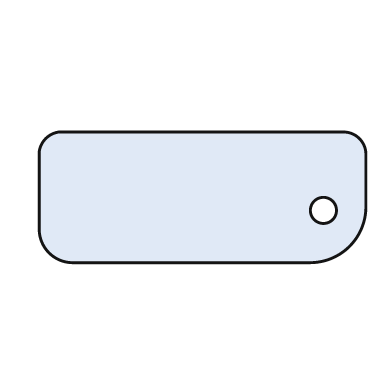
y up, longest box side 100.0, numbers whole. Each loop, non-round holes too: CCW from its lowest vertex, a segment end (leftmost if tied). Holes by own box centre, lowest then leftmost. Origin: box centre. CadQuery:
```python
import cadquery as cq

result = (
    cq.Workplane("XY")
    .moveTo(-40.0, -20.0)
    .lineTo(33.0, -20.0)
    .threePointArc((45.0, -15.0), (50.0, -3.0))
    .lineTo(50.0, 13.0)
    .threePointArc((48.0, 18.0), (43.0, 20.0))
    .lineTo(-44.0, 20.0)
    .threePointArc((-48.0, 18.0), (-50.0, 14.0))
    .lineTo(-50.0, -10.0)
    .threePointArc((-47.0, -17.0), (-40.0, -20.0))
    .close()
    .moveTo(37.0, -4.0)
    .circle(4.0)
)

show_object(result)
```